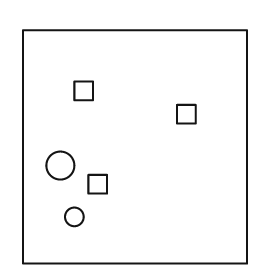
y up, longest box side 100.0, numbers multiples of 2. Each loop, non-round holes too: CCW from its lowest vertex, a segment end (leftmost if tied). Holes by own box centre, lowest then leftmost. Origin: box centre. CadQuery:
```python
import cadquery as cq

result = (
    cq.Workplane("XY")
    .moveTo(-48.0, -50.0)
    .lineTo(48.0, -50.0)
    .lineTo(48.0, 50.0)
    .lineTo(-48.0, 50.0)
    .close()
    .moveTo(-26.0, -30.0)
    .circle(4.0)
    .moveTo(-20.0, -20.0)
    .lineTo(-12.0, -20.0)
    .lineTo(-12.0, -12.0)
    .lineTo(-20.0, -12.0)
    .close()
    .moveTo(-32.0, -8.0)
    .circle(6.0)
    .moveTo(18.0, 10.0)
    .lineTo(26.0, 10.0)
    .lineTo(26.0, 18.0)
    .lineTo(18.0, 18.0)
    .close()
    .moveTo(-26.0, 20.0)
    .lineTo(-18.0, 20.0)
    .lineTo(-18.0, 28.0)
    .lineTo(-26.0, 28.0)
    .close()
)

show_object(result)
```